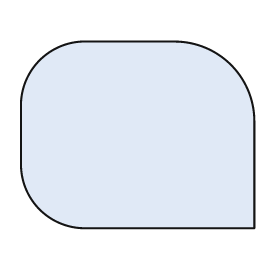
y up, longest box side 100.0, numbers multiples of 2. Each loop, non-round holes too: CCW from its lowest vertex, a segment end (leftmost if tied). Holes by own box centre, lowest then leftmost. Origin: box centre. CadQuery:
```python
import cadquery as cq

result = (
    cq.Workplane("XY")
    .moveTo(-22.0, -40.0)
    .lineTo(50.0, -40.0)
    .lineTo(50.0, 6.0)
    .threePointArc((40.0, 30.0), (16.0, 40.0))
    .lineTo(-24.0, 40.0)
    .threePointArc((-42.0, 32.0), (-50.0, 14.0))
    .lineTo(-50.0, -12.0)
    .threePointArc((-42.0, -32.0), (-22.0, -40.0))
    .close()
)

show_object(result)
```